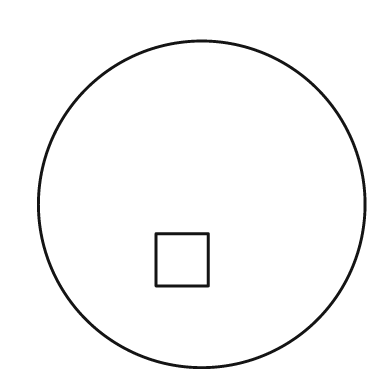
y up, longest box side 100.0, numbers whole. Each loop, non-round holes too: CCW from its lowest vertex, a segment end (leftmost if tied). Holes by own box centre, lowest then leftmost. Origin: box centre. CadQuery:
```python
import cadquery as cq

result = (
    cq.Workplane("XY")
    .moveTo(0.0, 0.0)
    .circle(50.0)
    .moveTo(-14.0, -25.0)
    .lineTo(2.0, -25.0)
    .lineTo(2.0, -9.0)
    .lineTo(-14.0, -9.0)
    .close()
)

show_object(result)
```